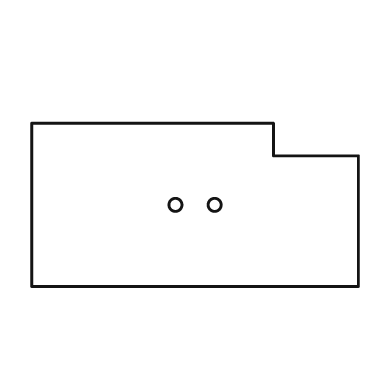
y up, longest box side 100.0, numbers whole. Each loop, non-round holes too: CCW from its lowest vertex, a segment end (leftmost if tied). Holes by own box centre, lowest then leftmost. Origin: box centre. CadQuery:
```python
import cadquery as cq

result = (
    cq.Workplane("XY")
    .moveTo(-50.0, -25.0)
    .lineTo(50.0, -25.0)
    .lineTo(50.0, 15.0)
    .lineTo(24.0, 15.0)
    .lineTo(24.0, 25.0)
    .lineTo(-50.0, 25.0)
    .close()
    .moveTo(-6.0, 0.0)
    .circle(2.0)
    .moveTo(6.0, 0.0)
    .circle(2.0)
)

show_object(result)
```